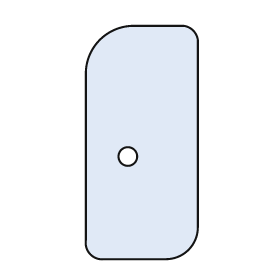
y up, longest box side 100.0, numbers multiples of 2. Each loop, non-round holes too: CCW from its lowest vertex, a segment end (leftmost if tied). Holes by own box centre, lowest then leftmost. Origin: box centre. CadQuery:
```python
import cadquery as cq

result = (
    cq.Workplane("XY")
    .moveTo(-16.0, -50.0)
    .lineTo(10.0, -50.0)
    .threePointArc((20.0, -46.0), (24.0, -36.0))
    .lineTo(24.0, 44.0)
    .threePointArc((22.0, 48.0), (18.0, 50.0))
    .lineTo(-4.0, 50.0)
    .threePointArc((-18.0, 44.0), (-24.0, 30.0))
    .lineTo(-24.0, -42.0)
    .threePointArc((-22.0, -48.0), (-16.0, -50.0))
    .close()
    .moveTo(-6.0, -6.0)
    .circle(4.0)
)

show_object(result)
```